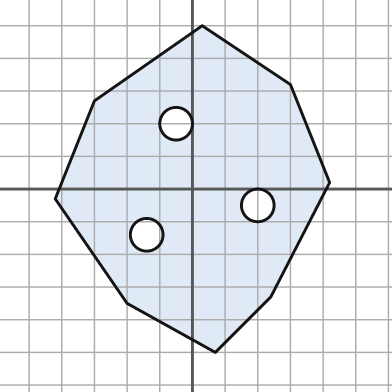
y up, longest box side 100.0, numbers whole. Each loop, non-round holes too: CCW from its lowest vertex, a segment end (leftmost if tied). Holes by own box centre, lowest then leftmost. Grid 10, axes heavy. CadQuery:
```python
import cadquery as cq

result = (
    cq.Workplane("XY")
    .moveTo(7.0, -50.0)
    .lineTo(24.0, -33.0)
    .lineTo(42.0, 2.0)
    .lineTo(30.0, 32.0)
    .lineTo(3.0, 50.0)
    .lineTo(-30.0, 27.0)
    .lineTo(-42.0, -3.0)
    .lineTo(-20.0, -35.0)
    .close()
    .moveTo(-14.0, -14.0)
    .circle(5.0)
    .moveTo(20.0, -5.0)
    .circle(5.0)
    .moveTo(-5.0, 20.0)
    .circle(5.0)
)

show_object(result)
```